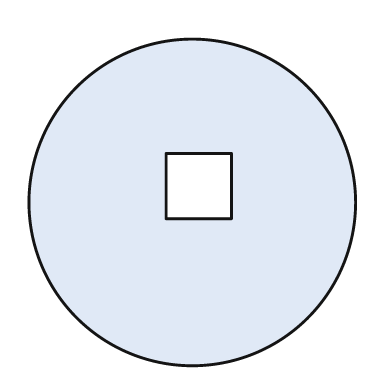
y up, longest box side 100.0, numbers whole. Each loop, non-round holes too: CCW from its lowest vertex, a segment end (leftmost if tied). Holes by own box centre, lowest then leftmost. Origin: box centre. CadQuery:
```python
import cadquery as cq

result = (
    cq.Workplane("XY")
    .moveTo(0.0, 0.0)
    .circle(50.0)
    .moveTo(-8.0, -5.0)
    .lineTo(12.0, -5.0)
    .lineTo(12.0, 15.0)
    .lineTo(-8.0, 15.0)
    .close()
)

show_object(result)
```